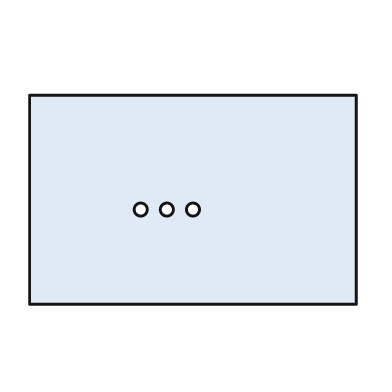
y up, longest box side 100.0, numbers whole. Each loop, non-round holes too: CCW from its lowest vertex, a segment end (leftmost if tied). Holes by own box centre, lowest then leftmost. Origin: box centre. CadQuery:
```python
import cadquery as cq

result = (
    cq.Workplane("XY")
    .moveTo(-50.0, -32.0)
    .lineTo(50.0, -32.0)
    .lineTo(50.0, 32.0)
    .lineTo(-50.0, 32.0)
    .close()
    .moveTo(-16.0, -3.0)
    .circle(2.0)
    .moveTo(-8.0, -3.0)
    .circle(2.0)
    .moveTo(0.0, -3.0)
    .circle(2.0)
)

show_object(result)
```